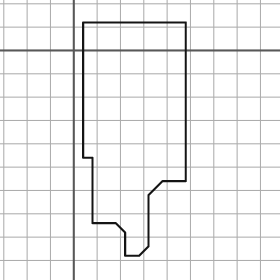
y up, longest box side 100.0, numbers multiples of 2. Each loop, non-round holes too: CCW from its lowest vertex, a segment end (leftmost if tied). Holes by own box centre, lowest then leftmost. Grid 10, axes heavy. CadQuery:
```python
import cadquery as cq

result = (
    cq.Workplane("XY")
    .moveTo(22.0, -88.0)
    .lineTo(28.0, -88.0)
    .lineTo(32.0, -84.0)
    .lineTo(32.0, -62.0)
    .lineTo(38.0, -56.0)
    .lineTo(48.0, -56.0)
    .lineTo(48.0, 12.0)
    .lineTo(4.0, 12.0)
    .lineTo(4.0, -46.0)
    .lineTo(8.0, -46.0)
    .lineTo(8.0, -74.0)
    .lineTo(18.0, -74.0)
    .lineTo(22.0, -78.0)
    .close()
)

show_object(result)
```